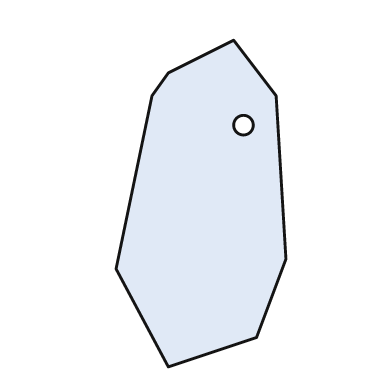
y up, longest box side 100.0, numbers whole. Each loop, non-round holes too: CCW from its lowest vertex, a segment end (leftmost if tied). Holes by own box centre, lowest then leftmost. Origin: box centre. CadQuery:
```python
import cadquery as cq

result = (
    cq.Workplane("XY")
    .moveTo(-10.0, -50.0)
    .lineTo(17.0, -41.0)
    .lineTo(26.0, -17.0)
    .lineTo(23.0, 33.0)
    .lineTo(10.0, 50.0)
    .lineTo(-10.0, 40.0)
    .lineTo(-15.0, 33.0)
    .lineTo(-26.0, -20.0)
    .close()
    .moveTo(13.0, 24.0)
    .circle(3.0)
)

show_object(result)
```